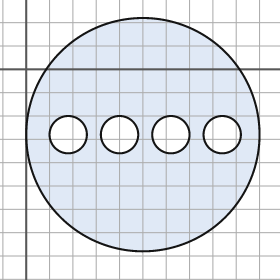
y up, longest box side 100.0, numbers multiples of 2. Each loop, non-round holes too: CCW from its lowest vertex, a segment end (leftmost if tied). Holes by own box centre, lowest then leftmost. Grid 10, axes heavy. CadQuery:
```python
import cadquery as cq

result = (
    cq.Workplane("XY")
    .moveTo(50.0, -28.0)
    .circle(50.0)
    .moveTo(18.0, -28.0)
    .circle(8.0)
    .moveTo(40.0, -28.0)
    .circle(8.0)
    .moveTo(62.0, -28.0)
    .circle(8.0)
    .moveTo(84.0, -28.0)
    .circle(8.0)
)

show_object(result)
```